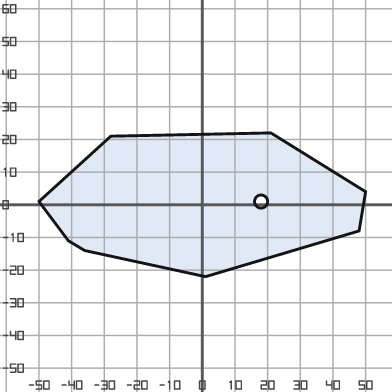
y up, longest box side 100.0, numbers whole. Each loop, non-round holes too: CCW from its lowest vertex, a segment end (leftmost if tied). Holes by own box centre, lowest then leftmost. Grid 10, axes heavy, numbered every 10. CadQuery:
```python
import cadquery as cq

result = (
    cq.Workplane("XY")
    .moveTo(1.0, -22.0)
    .lineTo(48.0, -8.0)
    .lineTo(50.0, 4.0)
    .lineTo(21.0, 22.0)
    .lineTo(-28.0, 21.0)
    .lineTo(-50.0, 1.0)
    .lineTo(-41.0, -11.0)
    .lineTo(-36.0, -14.0)
    .close()
    .moveTo(18.0, 1.0)
    .circle(2.0)
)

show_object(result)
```